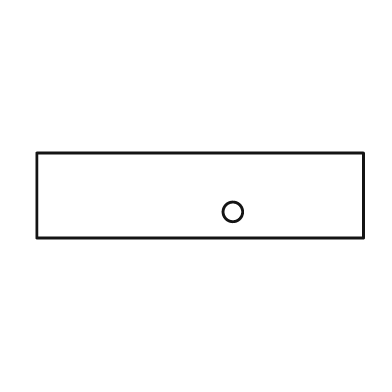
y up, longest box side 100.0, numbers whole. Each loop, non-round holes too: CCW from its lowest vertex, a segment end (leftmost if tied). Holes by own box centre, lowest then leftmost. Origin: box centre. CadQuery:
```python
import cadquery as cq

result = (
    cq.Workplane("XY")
    .moveTo(-50.0, -13.0)
    .lineTo(50.0, -13.0)
    .lineTo(50.0, 13.0)
    .lineTo(-50.0, 13.0)
    .close()
    .moveTo(10.0, -5.0)
    .circle(3.0)
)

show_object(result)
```